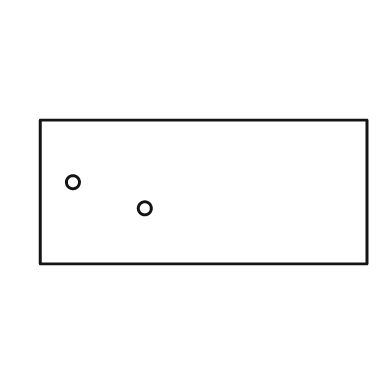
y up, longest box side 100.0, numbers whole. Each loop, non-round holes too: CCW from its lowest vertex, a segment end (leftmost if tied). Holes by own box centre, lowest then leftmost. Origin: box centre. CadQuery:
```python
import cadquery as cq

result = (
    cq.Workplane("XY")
    .moveTo(-50.0, -22.0)
    .lineTo(50.0, -22.0)
    .lineTo(50.0, 22.0)
    .lineTo(-50.0, 22.0)
    .close()
    .moveTo(-18.0, -5.0)
    .circle(2.0)
    .moveTo(-40.0, 3.0)
    .circle(2.0)
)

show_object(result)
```